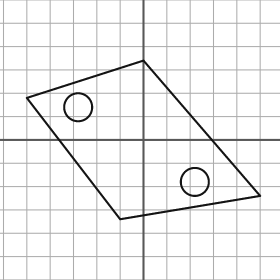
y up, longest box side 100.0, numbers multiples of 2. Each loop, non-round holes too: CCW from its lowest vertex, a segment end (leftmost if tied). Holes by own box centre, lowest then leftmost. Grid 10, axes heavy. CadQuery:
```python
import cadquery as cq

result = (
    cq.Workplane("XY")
    .moveTo(-10.0, -34.0)
    .lineTo(50.0, -24.0)
    .lineTo(0.0, 34.0)
    .lineTo(-50.0, 18.0)
    .close()
    .moveTo(22.0, -18.0)
    .circle(6.0)
    .moveTo(-28.0, 14.0)
    .circle(6.0)
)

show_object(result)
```